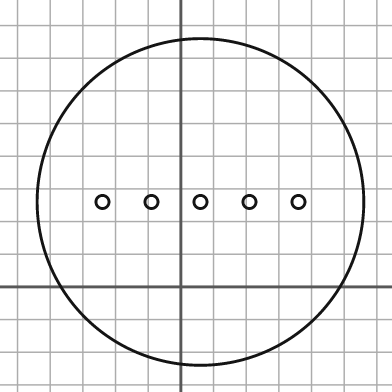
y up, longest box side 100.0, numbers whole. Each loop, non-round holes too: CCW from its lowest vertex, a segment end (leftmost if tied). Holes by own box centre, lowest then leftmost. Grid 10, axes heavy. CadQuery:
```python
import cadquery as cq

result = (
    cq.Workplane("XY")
    .moveTo(6.0, 26.0)
    .circle(50.0)
    .moveTo(-24.0, 26.0)
    .circle(2.0)
    .moveTo(-9.0, 26.0)
    .circle(2.0)
    .moveTo(6.0, 26.0)
    .circle(2.0)
    .moveTo(21.0, 26.0)
    .circle(2.0)
    .moveTo(36.0, 26.0)
    .circle(2.0)
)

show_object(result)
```